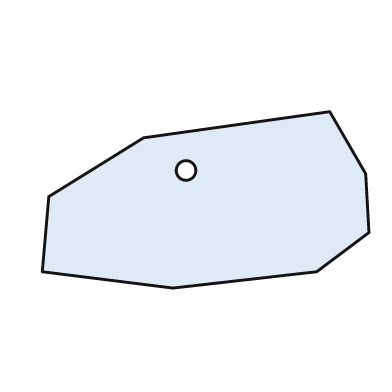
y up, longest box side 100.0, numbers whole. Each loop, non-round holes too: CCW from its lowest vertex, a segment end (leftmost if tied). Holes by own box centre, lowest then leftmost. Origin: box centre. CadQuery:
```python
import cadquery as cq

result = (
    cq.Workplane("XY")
    .moveTo(-10.0, -27.0)
    .lineTo(34.0, -22.0)
    .lineTo(50.0, -10.0)
    .lineTo(49.0, 8.0)
    .lineTo(38.0, 27.0)
    .lineTo(-19.0, 19.0)
    .lineTo(-48.0, 1.0)
    .lineTo(-50.0, -22.0)
    .close()
    .moveTo(-6.0, 9.0)
    .circle(3.0)
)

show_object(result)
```